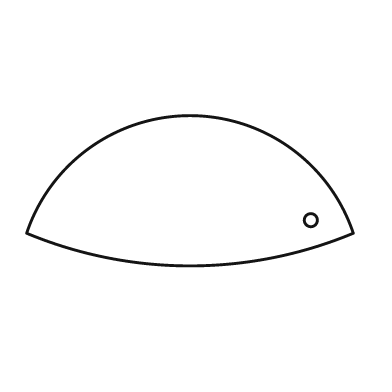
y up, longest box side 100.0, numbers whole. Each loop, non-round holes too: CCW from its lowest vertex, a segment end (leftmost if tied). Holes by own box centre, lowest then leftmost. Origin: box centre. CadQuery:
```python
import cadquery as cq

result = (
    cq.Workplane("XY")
    .moveTo(-50.0, -13.0)
    .threePointArc((0.0, -23.0), (50.0, -13.0))
    .threePointArc((0.0, 23.0), (-50.0, -13.0))
    .close()
    .moveTo(37.0, -9.0)
    .circle(2.0)
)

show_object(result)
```